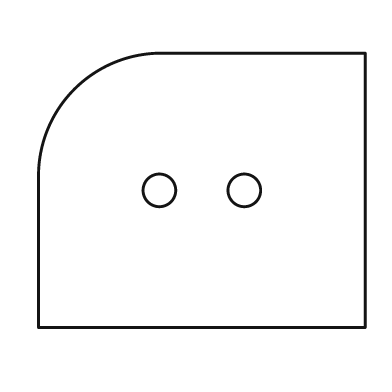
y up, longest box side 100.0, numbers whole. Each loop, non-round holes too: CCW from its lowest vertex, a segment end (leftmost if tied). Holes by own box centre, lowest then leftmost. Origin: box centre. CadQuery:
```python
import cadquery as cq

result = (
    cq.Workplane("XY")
    .moveTo(-50.0, -42.0)
    .lineTo(50.0, -42.0)
    .lineTo(50.0, 42.0)
    .lineTo(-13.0, 42.0)
    .threePointArc((-39.0, 31.0), (-50.0, 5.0))
    .close()
    .moveTo(-13.0, 0.0)
    .circle(5.0)
    .moveTo(13.0, 0.0)
    .circle(5.0)
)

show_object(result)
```